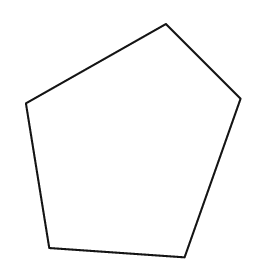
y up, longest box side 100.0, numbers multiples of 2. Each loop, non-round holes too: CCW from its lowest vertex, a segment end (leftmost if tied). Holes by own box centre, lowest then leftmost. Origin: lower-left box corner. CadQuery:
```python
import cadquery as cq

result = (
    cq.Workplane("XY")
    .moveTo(68.0, 0.0)
    .lineTo(92.0, 68.0)
    .lineTo(60.0, 100.0)
    .lineTo(0.0, 66.0)
    .lineTo(10.0, 4.0)
    .close()
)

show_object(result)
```